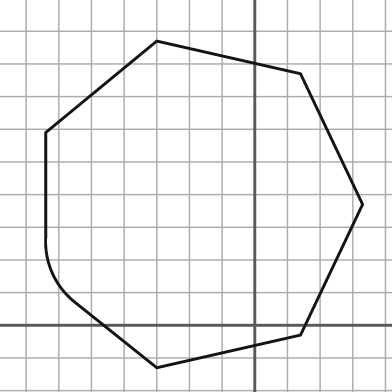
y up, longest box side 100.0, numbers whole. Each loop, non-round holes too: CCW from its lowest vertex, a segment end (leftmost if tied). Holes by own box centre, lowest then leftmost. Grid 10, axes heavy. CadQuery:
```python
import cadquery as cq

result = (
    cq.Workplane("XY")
    .moveTo(-30.0, -13.0)
    .lineTo(14.0, -3.0)
    .lineTo(33.0, 37.0)
    .lineTo(14.0, 77.0)
    .lineTo(-30.0, 87.0)
    .lineTo(-64.0, 59.0)
    .lineTo(-64.0, 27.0)
    .threePointArc((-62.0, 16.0), (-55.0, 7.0))
    .close()
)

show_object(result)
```